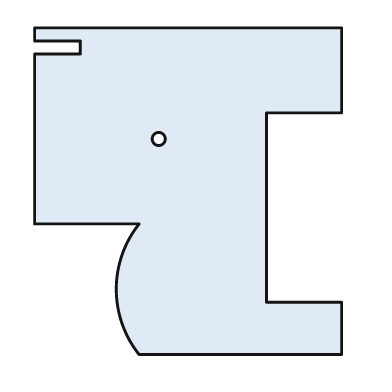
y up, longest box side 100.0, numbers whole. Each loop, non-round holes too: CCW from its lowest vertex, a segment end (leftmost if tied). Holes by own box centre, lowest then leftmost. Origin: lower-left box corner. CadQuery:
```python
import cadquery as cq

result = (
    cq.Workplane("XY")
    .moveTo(32.0, 0.0)
    .lineTo(94.0, 0.0)
    .lineTo(94.0, 16.0)
    .lineTo(71.0, 16.0)
    .lineTo(71.0, 74.0)
    .lineTo(94.0, 74.0)
    .lineTo(94.0, 100.0)
    .lineTo(0.0, 100.0)
    .lineTo(0.0, 96.0)
    .lineTo(14.0, 96.0)
    .lineTo(14.0, 92.0)
    .lineTo(0.0, 92.0)
    .lineTo(0.0, 40.0)
    .lineTo(32.0, 40.0)
    .threePointArc((25.0, 20.0), (32.0, 0.0))
    .close()
    .moveTo(38.0, 66.0)
    .circle(2.0)
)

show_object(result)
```